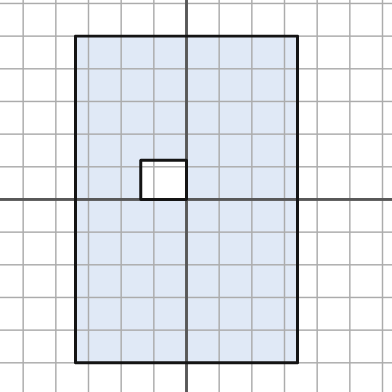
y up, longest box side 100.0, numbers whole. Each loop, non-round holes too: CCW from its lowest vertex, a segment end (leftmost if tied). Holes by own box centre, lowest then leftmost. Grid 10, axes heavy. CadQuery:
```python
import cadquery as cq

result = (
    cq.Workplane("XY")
    .moveTo(-34.0, -50.0)
    .lineTo(34.0, -50.0)
    .lineTo(34.0, 50.0)
    .lineTo(-34.0, 50.0)
    .close()
    .moveTo(-14.0, 0.0)
    .lineTo(0.0, 0.0)
    .lineTo(0.0, 12.0)
    .lineTo(-14.0, 12.0)
    .close()
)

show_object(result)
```